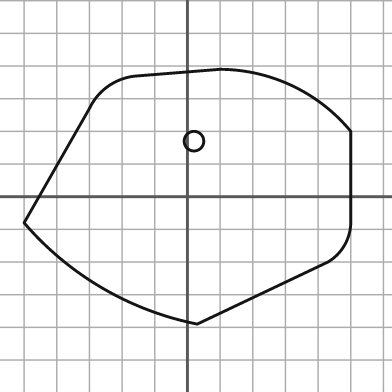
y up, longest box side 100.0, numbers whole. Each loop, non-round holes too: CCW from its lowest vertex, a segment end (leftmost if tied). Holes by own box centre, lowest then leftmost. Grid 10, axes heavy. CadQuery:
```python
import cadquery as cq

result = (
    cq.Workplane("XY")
    .moveTo(3.0, -39.0)
    .lineTo(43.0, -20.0)
    .threePointArc((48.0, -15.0), (50.0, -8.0))
    .lineTo(50.0, 20.0)
    .threePointArc((32.0, 34.0), (10.0, 39.0))
    .lineTo(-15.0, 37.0)
    .threePointArc((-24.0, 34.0), (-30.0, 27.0))
    .lineTo(-50.0, -8.0)
    .threePointArc((-26.0, -28.0), (3.0, -39.0))
    .close()
    .moveTo(2.0, 17.0)
    .circle(3.0)
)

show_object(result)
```